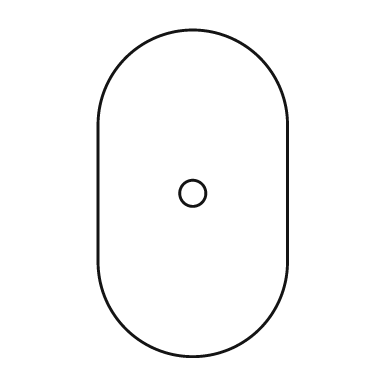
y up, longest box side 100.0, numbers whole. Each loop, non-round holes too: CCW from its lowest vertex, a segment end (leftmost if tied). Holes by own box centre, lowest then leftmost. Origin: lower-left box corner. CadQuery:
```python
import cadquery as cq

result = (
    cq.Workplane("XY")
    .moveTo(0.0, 29.0)
    .threePointArc((29.0, 0.0), (58.0, 29.0))
    .lineTo(58.0, 71.0)
    .threePointArc((29.0, 100.0), (0.0, 71.0))
    .close()
    .moveTo(29.0, 50.0)
    .circle(4.0)
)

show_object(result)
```